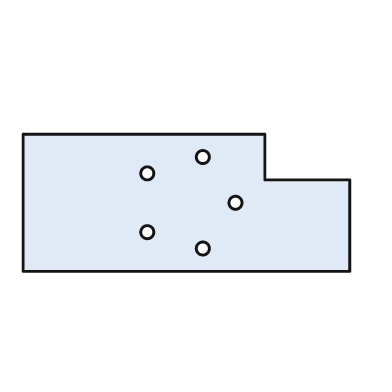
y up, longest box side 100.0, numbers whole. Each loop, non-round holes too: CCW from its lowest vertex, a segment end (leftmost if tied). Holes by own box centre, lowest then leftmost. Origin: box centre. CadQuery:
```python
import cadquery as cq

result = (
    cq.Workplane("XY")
    .moveTo(-50.0, -21.0)
    .lineTo(50.0, -21.0)
    .lineTo(50.0, 7.0)
    .lineTo(24.0, 7.0)
    .lineTo(24.0, 21.0)
    .lineTo(-50.0, 21.0)
    .close()
    .moveTo(5.0, -14.0)
    .circle(2.0)
    .moveTo(-12.0, -9.0)
    .circle(2.0)
    .moveTo(15.0, 0.0)
    .circle(2.0)
    .moveTo(-12.0, 9.0)
    .circle(2.0)
    .moveTo(5.0, 14.0)
    .circle(2.0)
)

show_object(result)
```